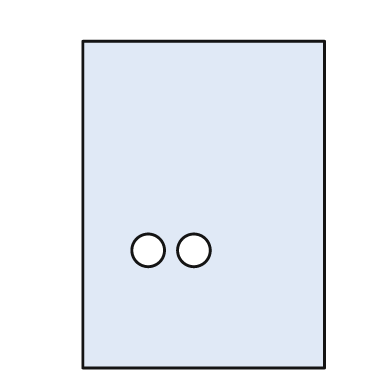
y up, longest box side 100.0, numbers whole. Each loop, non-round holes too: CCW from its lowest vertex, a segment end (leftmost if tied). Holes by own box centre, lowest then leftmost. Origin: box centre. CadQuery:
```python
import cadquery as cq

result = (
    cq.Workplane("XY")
    .moveTo(-37.0, -50.0)
    .lineTo(37.0, -50.0)
    .lineTo(37.0, 50.0)
    .lineTo(-37.0, 50.0)
    .close()
    .moveTo(-17.0, -14.0)
    .circle(5.0)
    .moveTo(-3.0, -14.0)
    .circle(5.0)
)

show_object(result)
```